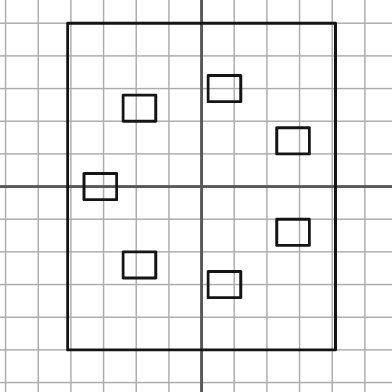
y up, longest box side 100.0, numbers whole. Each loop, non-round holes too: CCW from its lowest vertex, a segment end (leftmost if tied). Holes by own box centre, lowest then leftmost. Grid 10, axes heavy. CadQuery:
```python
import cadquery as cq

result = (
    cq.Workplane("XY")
    .moveTo(-41.0, -50.0)
    .lineTo(41.0, -50.0)
    .lineTo(41.0, 50.0)
    .lineTo(-41.0, 50.0)
    .close()
    .moveTo(2.0, -34.0)
    .lineTo(12.0, -34.0)
    .lineTo(12.0, -26.0)
    .lineTo(2.0, -26.0)
    .close()
    .moveTo(-24.0, -28.0)
    .lineTo(-14.0, -28.0)
    .lineTo(-14.0, -20.0)
    .lineTo(-24.0, -20.0)
    .close()
    .moveTo(23.0, -18.0)
    .lineTo(33.0, -18.0)
    .lineTo(33.0, -10.0)
    .lineTo(23.0, -10.0)
    .close()
    .moveTo(-36.0, -4.0)
    .lineTo(-26.0, -4.0)
    .lineTo(-26.0, 4.0)
    .lineTo(-36.0, 4.0)
    .close()
    .moveTo(23.0, 10.0)
    .lineTo(33.0, 10.0)
    .lineTo(33.0, 18.0)
    .lineTo(23.0, 18.0)
    .close()
    .moveTo(-24.0, 20.0)
    .lineTo(-14.0, 20.0)
    .lineTo(-14.0, 28.0)
    .lineTo(-24.0, 28.0)
    .close()
    .moveTo(2.0, 26.0)
    .lineTo(12.0, 26.0)
    .lineTo(12.0, 34.0)
    .lineTo(2.0, 34.0)
    .close()
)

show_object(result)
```